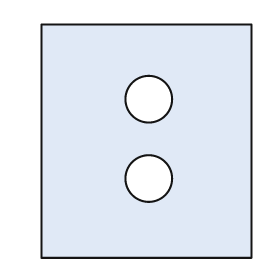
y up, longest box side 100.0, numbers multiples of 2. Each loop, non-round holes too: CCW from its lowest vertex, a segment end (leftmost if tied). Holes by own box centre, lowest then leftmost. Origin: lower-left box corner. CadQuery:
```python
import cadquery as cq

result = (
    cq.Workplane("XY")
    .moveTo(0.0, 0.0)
    .lineTo(90.0, 0.0)
    .lineTo(90.0, 100.0)
    .lineTo(0.0, 100.0)
    .close()
    .moveTo(46.0, 34.0)
    .circle(10.0)
    .moveTo(46.0, 68.0)
    .circle(10.0)
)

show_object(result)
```